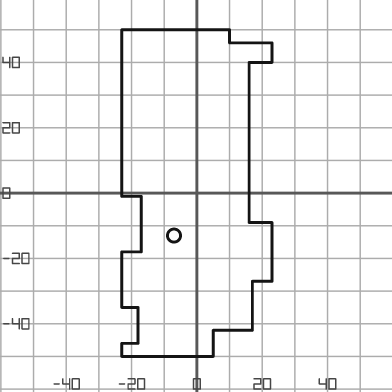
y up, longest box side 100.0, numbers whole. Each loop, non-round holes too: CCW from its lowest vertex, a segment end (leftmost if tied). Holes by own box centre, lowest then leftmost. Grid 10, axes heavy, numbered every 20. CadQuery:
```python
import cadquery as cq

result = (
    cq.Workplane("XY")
    .moveTo(-23.0, -50.0)
    .lineTo(5.0, -50.0)
    .lineTo(5.0, -42.0)
    .lineTo(17.0, -42.0)
    .lineTo(17.0, -27.0)
    .lineTo(23.0, -27.0)
    .lineTo(23.0, -9.0)
    .lineTo(16.0, -9.0)
    .lineTo(16.0, 40.0)
    .lineTo(23.0, 40.0)
    .lineTo(23.0, 46.0)
    .lineTo(10.0, 46.0)
    .lineTo(10.0, 50.0)
    .lineTo(-23.0, 50.0)
    .lineTo(-23.0, -1.0)
    .lineTo(-17.0, -1.0)
    .lineTo(-17.0, -18.0)
    .lineTo(-23.0, -18.0)
    .lineTo(-23.0, -35.0)
    .lineTo(-18.0, -35.0)
    .lineTo(-18.0, -46.0)
    .lineTo(-23.0, -46.0)
    .close()
    .moveTo(-7.0, -13.0)
    .circle(2.0)
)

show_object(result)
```